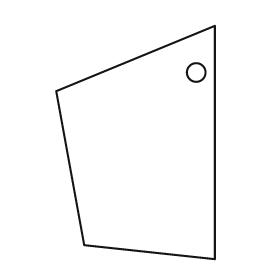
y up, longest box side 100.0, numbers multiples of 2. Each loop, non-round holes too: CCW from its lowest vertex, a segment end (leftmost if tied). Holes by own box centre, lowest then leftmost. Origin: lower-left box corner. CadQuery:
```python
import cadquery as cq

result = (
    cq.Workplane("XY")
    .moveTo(68.0, 0.0)
    .lineTo(68.0, 100.0)
    .lineTo(0.0, 72.0)
    .lineTo(12.0, 6.0)
    .close()
    .moveTo(60.0, 80.0)
    .circle(4.0)
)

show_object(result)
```